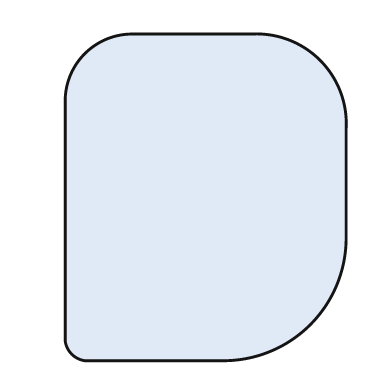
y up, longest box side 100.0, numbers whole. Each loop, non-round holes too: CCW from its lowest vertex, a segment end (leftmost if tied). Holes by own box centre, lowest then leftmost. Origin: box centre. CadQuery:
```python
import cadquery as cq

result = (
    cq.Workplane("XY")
    .moveTo(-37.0, -50.0)
    .lineTo(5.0, -50.0)
    .threePointArc((32.0, -39.0), (43.0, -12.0))
    .lineTo(43.0, 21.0)
    .threePointArc((35.0, 42.0), (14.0, 50.0))
    .lineTo(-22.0, 50.0)
    .threePointArc((-37.0, 44.0), (-43.0, 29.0))
    .lineTo(-43.0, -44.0)
    .threePointArc((-41.0, -48.0), (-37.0, -50.0))
    .close()
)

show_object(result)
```